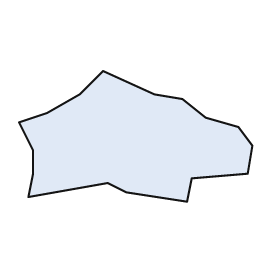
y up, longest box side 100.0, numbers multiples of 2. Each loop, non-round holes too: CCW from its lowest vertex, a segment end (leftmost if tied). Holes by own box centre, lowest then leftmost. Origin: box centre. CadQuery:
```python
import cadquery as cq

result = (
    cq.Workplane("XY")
    .moveTo(22.0, -28.0)
    .lineTo(24.0, -18.0)
    .lineTo(48.0, -16.0)
    .lineTo(50.0, -4.0)
    .lineTo(44.0, 4.0)
    .lineTo(30.0, 8.0)
    .lineTo(20.0, 16.0)
    .lineTo(8.0, 18.0)
    .lineTo(-14.0, 28.0)
    .lineTo(-24.0, 18.0)
    .lineTo(-38.0, 10.0)
    .lineTo(-50.0, 6.0)
    .lineTo(-44.0, -6.0)
    .lineTo(-44.0, -16.0)
    .lineTo(-46.0, -26.0)
    .lineTo(-12.0, -20.0)
    .lineTo(-4.0, -24.0)
    .close()
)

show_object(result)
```